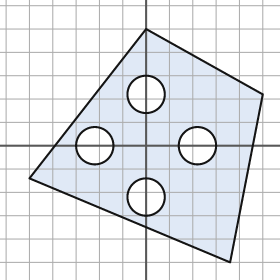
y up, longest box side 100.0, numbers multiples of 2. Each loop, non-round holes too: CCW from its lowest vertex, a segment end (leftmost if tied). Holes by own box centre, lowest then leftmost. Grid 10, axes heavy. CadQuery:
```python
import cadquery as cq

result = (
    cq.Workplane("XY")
    .moveTo(36.0, -50.0)
    .lineTo(50.0, 22.0)
    .lineTo(0.0, 50.0)
    .lineTo(-50.0, -14.0)
    .close()
    .moveTo(0.0, -22.0)
    .circle(8.0)
    .moveTo(-22.0, 0.0)
    .circle(8.0)
    .moveTo(22.0, 0.0)
    .circle(8.0)
    .moveTo(0.0, 22.0)
    .circle(8.0)
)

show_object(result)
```